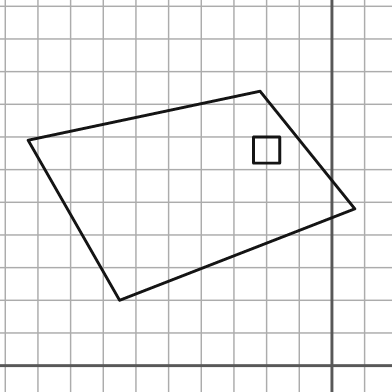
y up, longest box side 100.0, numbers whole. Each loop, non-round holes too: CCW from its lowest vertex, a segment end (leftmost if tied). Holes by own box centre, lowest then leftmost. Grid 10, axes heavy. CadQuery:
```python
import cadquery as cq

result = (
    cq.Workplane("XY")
    .moveTo(-65.0, 20.0)
    .lineTo(7.0, 48.0)
    .lineTo(-22.0, 84.0)
    .lineTo(-93.0, 69.0)
    .close()
    .moveTo(-24.0, 62.0)
    .lineTo(-16.0, 62.0)
    .lineTo(-16.0, 70.0)
    .lineTo(-24.0, 70.0)
    .close()
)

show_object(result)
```